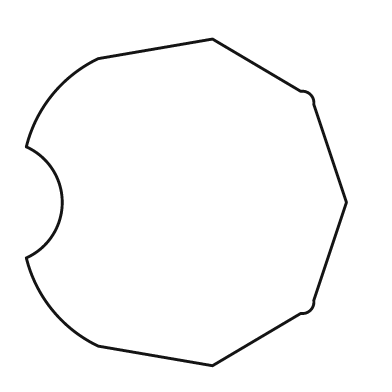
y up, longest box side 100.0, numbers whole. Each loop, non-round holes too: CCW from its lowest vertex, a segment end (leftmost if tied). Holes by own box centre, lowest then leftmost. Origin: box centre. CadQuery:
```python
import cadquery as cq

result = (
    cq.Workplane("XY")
    .moveTo(8.0, -50.0)
    .lineTo(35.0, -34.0)
    .threePointArc((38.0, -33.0), (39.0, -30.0))
    .lineTo(49.0, 0.0)
    .lineTo(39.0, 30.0)
    .threePointArc((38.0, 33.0), (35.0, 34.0))
    .lineTo(8.0, 50.0)
    .lineTo(-27.0, 44.0)
    .threePointArc((-41.0, 33.0), (-49.0, 17.0))
    .threePointArc((-38.0, 0.0), (-49.0, -17.0))
    .threePointArc((-41.0, -33.0), (-27.0, -44.0))
    .close()
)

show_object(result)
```